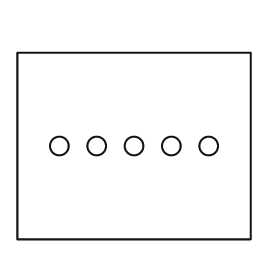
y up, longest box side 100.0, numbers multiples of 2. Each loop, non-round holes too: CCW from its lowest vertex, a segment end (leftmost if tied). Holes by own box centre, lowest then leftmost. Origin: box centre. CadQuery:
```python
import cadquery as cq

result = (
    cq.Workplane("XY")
    .moveTo(-50.0, -40.0)
    .lineTo(50.0, -40.0)
    .lineTo(50.0, 40.0)
    .lineTo(-50.0, 40.0)
    .close()
    .moveTo(-32.0, 0.0)
    .circle(4.0)
    .moveTo(-16.0, 0.0)
    .circle(4.0)
    .moveTo(0.0, 0.0)
    .circle(4.0)
    .moveTo(16.0, 0.0)
    .circle(4.0)
    .moveTo(32.0, 0.0)
    .circle(4.0)
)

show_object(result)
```